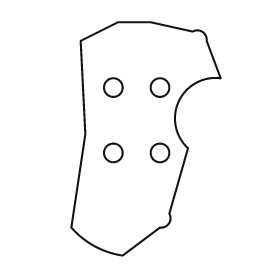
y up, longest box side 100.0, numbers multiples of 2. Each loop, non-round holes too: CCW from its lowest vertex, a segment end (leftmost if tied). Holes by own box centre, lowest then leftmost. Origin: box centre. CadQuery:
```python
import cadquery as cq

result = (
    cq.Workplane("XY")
    .moveTo(-10.0, -50.0)
    .lineTo(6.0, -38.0)
    .threePointArc((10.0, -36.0), (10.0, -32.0))
    .lineTo(18.0, -4.0)
    .threePointArc((14.0, 16.0), (32.0, 26.0))
    .lineTo(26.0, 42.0)
    .threePointArc((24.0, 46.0), (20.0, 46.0))
    .lineTo(2.0, 50.0)
    .lineTo(-12.0, 50.0)
    .lineTo(-28.0, 42.0)
    .lineTo(-26.0, 2.0)
    .lineTo(-32.0, -38.0)
    .threePointArc((-22.0, -46.0), (-10.0, -50.0))
    .close()
    .moveTo(-14.0, -6.0)
    .circle(4.0)
    .moveTo(6.0, -6.0)
    .circle(4.0)
    .moveTo(-14.0, 22.0)
    .circle(4.0)
    .moveTo(6.0, 22.0)
    .circle(4.0)
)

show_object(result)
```